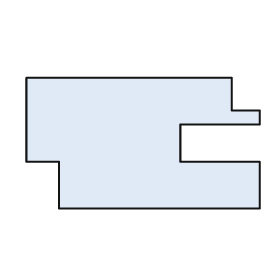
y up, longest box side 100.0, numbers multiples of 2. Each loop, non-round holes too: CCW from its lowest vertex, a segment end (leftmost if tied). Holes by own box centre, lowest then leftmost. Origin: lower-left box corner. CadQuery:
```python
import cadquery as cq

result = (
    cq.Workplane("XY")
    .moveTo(14.0, 0.0)
    .lineTo(100.0, 0.0)
    .lineTo(100.0, 20.0)
    .lineTo(66.0, 20.0)
    .lineTo(66.0, 36.0)
    .lineTo(100.0, 36.0)
    .lineTo(100.0, 42.0)
    .lineTo(88.0, 42.0)
    .lineTo(88.0, 56.0)
    .lineTo(0.0, 56.0)
    .lineTo(0.0, 20.0)
    .lineTo(14.0, 20.0)
    .close()
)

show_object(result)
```